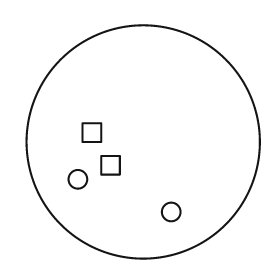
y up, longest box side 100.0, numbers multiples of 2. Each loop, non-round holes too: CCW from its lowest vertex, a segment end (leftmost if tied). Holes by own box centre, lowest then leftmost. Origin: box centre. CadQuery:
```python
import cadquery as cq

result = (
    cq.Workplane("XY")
    .moveTo(0.0, 0.0)
    .circle(50.0)
    .moveTo(12.0, -30.0)
    .circle(4.0)
    .moveTo(-28.0, -16.0)
    .circle(4.0)
    .moveTo(-18.0, -14.0)
    .lineTo(-10.0, -14.0)
    .lineTo(-10.0, -6.0)
    .lineTo(-18.0, -6.0)
    .close()
    .moveTo(-26.0, 0.0)
    .lineTo(-18.0, 0.0)
    .lineTo(-18.0, 8.0)
    .lineTo(-26.0, 8.0)
    .close()
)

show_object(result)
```